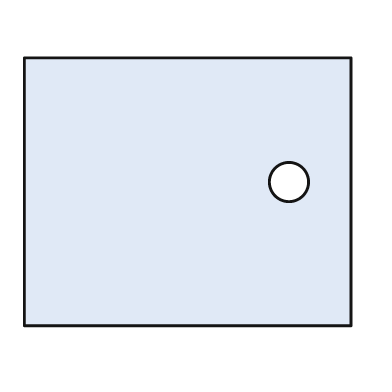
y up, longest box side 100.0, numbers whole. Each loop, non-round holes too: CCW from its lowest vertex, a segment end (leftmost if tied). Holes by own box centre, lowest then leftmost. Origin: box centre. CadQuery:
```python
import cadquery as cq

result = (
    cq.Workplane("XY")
    .moveTo(-50.0, -41.0)
    .lineTo(50.0, -41.0)
    .lineTo(50.0, 41.0)
    .lineTo(-50.0, 41.0)
    .close()
    .moveTo(31.0, 3.0)
    .circle(6.0)
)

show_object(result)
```